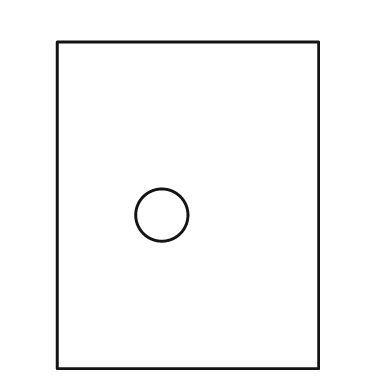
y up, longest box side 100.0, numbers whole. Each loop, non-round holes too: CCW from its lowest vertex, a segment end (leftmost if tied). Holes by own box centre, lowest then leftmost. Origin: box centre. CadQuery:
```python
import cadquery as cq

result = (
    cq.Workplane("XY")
    .moveTo(-40.0, -50.0)
    .lineTo(40.0, -50.0)
    .lineTo(40.0, 50.0)
    .lineTo(-40.0, 50.0)
    .close()
    .moveTo(-8.0, -3.0)
    .circle(8.0)
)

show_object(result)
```